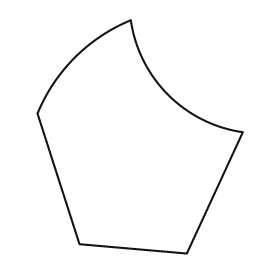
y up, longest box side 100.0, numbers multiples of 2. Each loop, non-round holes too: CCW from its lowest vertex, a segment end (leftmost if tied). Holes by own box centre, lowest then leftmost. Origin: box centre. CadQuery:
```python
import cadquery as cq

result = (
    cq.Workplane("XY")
    .moveTo(20.0, -50.0)
    .lineTo(44.0, 2.0)
    .threePointArc((12.0, 18.0), (-4.0, 50.0))
    .threePointArc((-28.0, 34.0), (-44.0, 10.0))
    .lineTo(-26.0, -46.0)
    .close()
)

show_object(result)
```